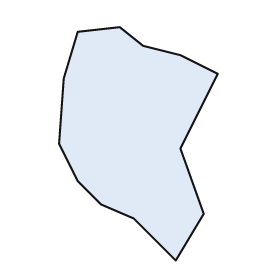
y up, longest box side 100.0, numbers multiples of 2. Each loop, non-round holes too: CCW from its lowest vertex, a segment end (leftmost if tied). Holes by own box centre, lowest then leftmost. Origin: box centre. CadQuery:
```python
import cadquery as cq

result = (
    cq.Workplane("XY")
    .moveTo(16.0, -50.0)
    .lineTo(28.0, -30.0)
    .lineTo(18.0, -2.0)
    .lineTo(34.0, 30.0)
    .lineTo(18.0, 38.0)
    .lineTo(2.0, 42.0)
    .lineTo(-8.0, 50.0)
    .lineTo(-26.0, 48.0)
    .lineTo(-32.0, 28.0)
    .lineTo(-34.0, 0.0)
    .lineTo(-26.0, -16.0)
    .lineTo(-16.0, -26.0)
    .lineTo(-2.0, -32.0)
    .close()
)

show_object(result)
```